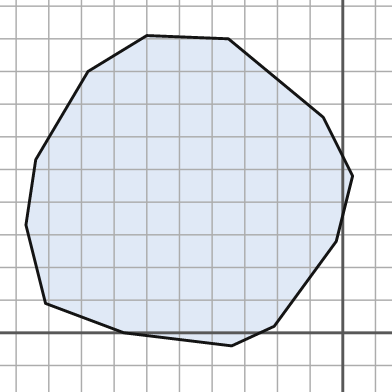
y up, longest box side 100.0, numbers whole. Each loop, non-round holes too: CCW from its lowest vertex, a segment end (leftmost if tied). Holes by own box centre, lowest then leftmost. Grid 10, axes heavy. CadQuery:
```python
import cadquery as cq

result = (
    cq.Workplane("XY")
    .moveTo(-34.0, -4.0)
    .lineTo(-21.0, 2.0)
    .lineTo(-2.0, 28.0)
    .lineTo(3.0, 48.0)
    .lineTo(-6.0, 66.0)
    .lineTo(-35.0, 90.0)
    .lineTo(-60.0, 91.0)
    .lineTo(-78.0, 80.0)
    .lineTo(-94.0, 53.0)
    .lineTo(-97.0, 33.0)
    .lineTo(-91.0, 9.0)
    .lineTo(-67.0, 0.0)
    .close()
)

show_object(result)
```